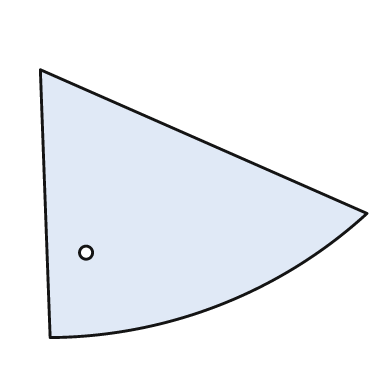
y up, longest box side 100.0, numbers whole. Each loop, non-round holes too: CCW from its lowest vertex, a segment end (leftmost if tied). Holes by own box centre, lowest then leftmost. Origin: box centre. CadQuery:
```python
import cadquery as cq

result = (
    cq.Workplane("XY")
    .moveTo(-47.0, -41.0)
    .threePointArc((5.0, -31.0), (50.0, -3.0))
    .lineTo(-50.0, 41.0)
    .close()
    .moveTo(-36.0, -15.0)
    .circle(2.0)
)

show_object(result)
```